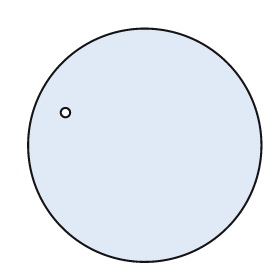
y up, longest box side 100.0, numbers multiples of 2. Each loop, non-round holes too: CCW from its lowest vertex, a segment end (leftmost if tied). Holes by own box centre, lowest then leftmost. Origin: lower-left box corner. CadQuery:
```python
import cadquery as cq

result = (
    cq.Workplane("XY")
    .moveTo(50.0, 50.0)
    .circle(50.0)
    .moveTo(16.0, 64.0)
    .circle(2.0)
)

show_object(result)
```